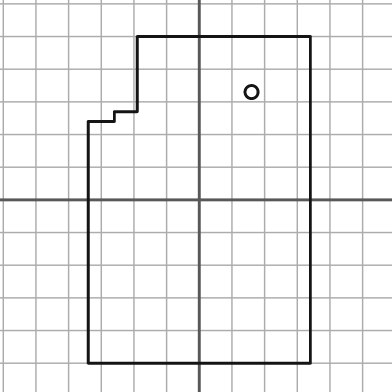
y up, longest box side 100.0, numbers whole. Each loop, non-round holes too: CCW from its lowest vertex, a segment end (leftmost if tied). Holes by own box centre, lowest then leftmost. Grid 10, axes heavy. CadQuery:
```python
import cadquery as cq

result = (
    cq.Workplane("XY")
    .moveTo(-34.0, -50.0)
    .lineTo(34.0, -50.0)
    .lineTo(34.0, 50.0)
    .lineTo(-19.0, 50.0)
    .lineTo(-19.0, 27.0)
    .lineTo(-26.0, 27.0)
    .lineTo(-26.0, 24.0)
    .lineTo(-34.0, 24.0)
    .close()
    .moveTo(16.0, 33.0)
    .circle(2.0)
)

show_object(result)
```